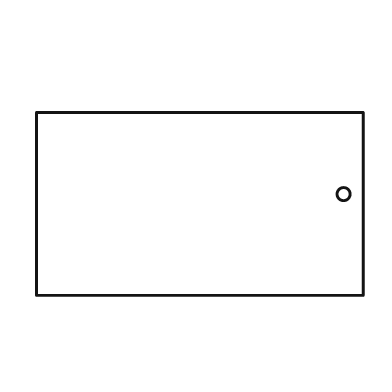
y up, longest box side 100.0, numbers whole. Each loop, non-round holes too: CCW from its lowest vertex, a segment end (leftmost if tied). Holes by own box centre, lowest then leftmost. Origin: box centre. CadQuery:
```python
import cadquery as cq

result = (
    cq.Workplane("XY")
    .moveTo(-50.0, -28.0)
    .lineTo(50.0, -28.0)
    .lineTo(50.0, 28.0)
    .lineTo(-50.0, 28.0)
    .close()
    .moveTo(44.0, 3.0)
    .circle(2.0)
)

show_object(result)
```